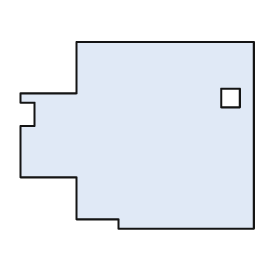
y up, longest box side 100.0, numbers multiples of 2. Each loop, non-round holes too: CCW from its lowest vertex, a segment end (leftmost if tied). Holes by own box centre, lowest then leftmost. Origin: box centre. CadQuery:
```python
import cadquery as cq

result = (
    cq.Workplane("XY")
    .moveTo(-8.0, -40.0)
    .lineTo(50.0, -40.0)
    .lineTo(50.0, 40.0)
    .lineTo(-26.0, 40.0)
    .lineTo(-26.0, 18.0)
    .lineTo(-50.0, 18.0)
    .lineTo(-50.0, 14.0)
    .lineTo(-44.0, 14.0)
    .lineTo(-44.0, 4.0)
    .lineTo(-50.0, 4.0)
    .lineTo(-50.0, -18.0)
    .lineTo(-26.0, -18.0)
    .lineTo(-26.0, -36.0)
    .lineTo(-8.0, -36.0)
    .close()
    .moveTo(36.0, 12.0)
    .lineTo(44.0, 12.0)
    .lineTo(44.0, 20.0)
    .lineTo(36.0, 20.0)
    .close()
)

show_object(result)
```